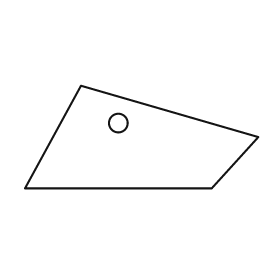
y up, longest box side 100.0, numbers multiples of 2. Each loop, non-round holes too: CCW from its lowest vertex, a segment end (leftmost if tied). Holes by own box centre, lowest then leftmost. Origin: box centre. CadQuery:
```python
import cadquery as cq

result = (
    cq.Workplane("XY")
    .moveTo(-50.0, -22.0)
    .lineTo(30.0, -22.0)
    .lineTo(50.0, 0.0)
    .lineTo(-26.0, 22.0)
    .close()
    .moveTo(-10.0, 6.0)
    .circle(4.0)
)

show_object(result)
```